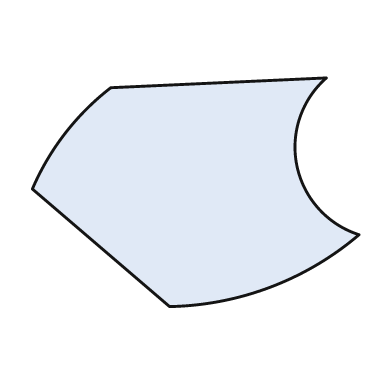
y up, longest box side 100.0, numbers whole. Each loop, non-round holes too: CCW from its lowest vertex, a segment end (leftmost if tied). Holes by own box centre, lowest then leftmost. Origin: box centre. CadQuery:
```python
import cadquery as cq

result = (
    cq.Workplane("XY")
    .moveTo(-8.0, -35.0)
    .threePointArc((23.0, -29.0), (50.0, -13.0))
    .threePointArc((31.0, 8.0), (40.0, 35.0))
    .lineTo(-26.0, 32.0)
    .threePointArc((-40.0, 18.0), (-50.0, 1.0))
    .close()
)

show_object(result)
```